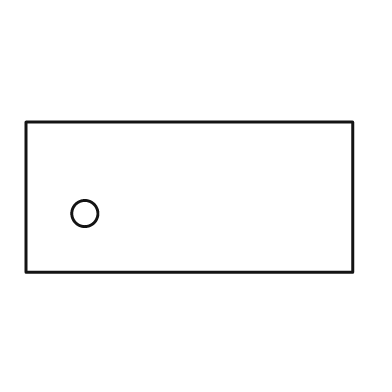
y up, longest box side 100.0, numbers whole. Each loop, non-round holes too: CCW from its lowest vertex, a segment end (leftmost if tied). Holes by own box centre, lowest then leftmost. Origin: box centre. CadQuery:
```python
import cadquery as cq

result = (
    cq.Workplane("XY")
    .moveTo(-50.0, -23.0)
    .lineTo(50.0, -23.0)
    .lineTo(50.0, 23.0)
    .lineTo(-50.0, 23.0)
    .close()
    .moveTo(-32.0, -5.0)
    .circle(4.0)
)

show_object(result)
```